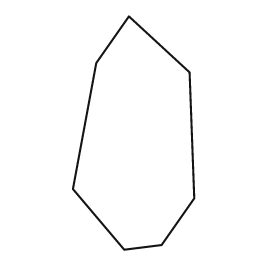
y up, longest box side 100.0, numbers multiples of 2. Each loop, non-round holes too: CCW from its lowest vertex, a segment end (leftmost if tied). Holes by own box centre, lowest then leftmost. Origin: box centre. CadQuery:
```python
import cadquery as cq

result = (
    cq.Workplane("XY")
    .moveTo(-4.0, -50.0)
    .lineTo(12.0, -48.0)
    .lineTo(26.0, -28.0)
    .lineTo(24.0, 26.0)
    .lineTo(-2.0, 50.0)
    .lineTo(-16.0, 30.0)
    .lineTo(-26.0, -24.0)
    .close()
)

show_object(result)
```